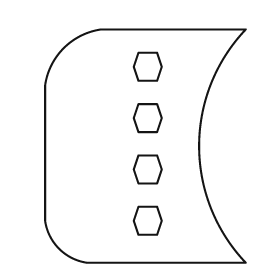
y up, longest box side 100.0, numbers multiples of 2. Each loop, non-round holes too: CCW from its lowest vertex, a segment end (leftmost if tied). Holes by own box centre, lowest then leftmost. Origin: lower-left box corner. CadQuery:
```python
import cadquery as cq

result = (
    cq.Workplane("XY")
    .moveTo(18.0, 0.0)
    .lineTo(86.0, 0.0)
    .threePointArc((66.0, 50.0), (86.0, 100.0))
    .lineTo(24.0, 100.0)
    .threePointArc((8.0, 92.0), (0.0, 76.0))
    .lineTo(0.0, 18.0)
    .threePointArc((6.0, 6.0), (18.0, 0.0))
    .close()
    .moveTo(40.0, 12.0)
    .lineTo(48.0, 12.0)
    .lineTo(50.0, 18.0)
    .lineTo(48.0, 24.0)
    .lineTo(40.0, 24.0)
    .lineTo(38.0, 18.0)
    .close()
    .moveTo(40.0, 34.0)
    .lineTo(48.0, 34.0)
    .lineTo(50.0, 40.0)
    .lineTo(48.0, 46.0)
    .lineTo(40.0, 46.0)
    .lineTo(38.0, 40.0)
    .close()
    .moveTo(40.0, 56.0)
    .lineTo(48.0, 56.0)
    .lineTo(50.0, 62.0)
    .lineTo(48.0, 68.0)
    .lineTo(40.0, 68.0)
    .lineTo(38.0, 62.0)
    .close()
    .moveTo(40.0, 78.0)
    .lineTo(48.0, 78.0)
    .lineTo(50.0, 84.0)
    .lineTo(48.0, 90.0)
    .lineTo(40.0, 90.0)
    .lineTo(38.0, 84.0)
    .close()
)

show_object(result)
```